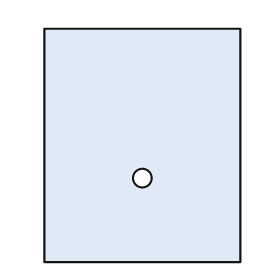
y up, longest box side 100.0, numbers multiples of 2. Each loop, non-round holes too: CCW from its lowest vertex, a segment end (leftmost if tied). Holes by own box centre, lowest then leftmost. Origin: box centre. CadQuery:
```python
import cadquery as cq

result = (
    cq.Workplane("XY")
    .moveTo(-42.0, -50.0)
    .lineTo(42.0, -50.0)
    .lineTo(42.0, 50.0)
    .lineTo(-42.0, 50.0)
    .close()
    .moveTo(0.0, -14.0)
    .circle(4.0)
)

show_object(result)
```